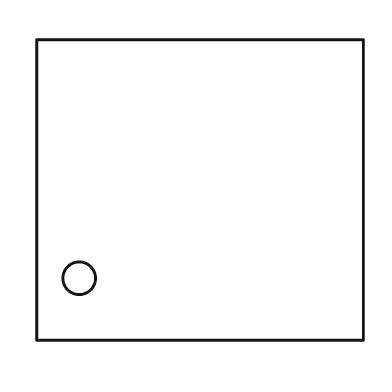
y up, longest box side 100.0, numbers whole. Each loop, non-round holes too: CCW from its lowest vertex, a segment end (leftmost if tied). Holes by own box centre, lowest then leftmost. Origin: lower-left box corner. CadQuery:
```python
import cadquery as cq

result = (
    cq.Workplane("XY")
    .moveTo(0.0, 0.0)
    .lineTo(100.0, 0.0)
    .lineTo(100.0, 92.0)
    .lineTo(0.0, 92.0)
    .close()
    .moveTo(13.0, 19.0)
    .circle(5.0)
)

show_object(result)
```